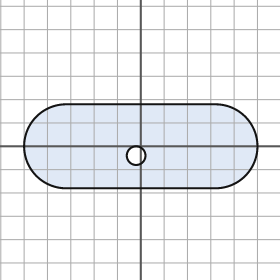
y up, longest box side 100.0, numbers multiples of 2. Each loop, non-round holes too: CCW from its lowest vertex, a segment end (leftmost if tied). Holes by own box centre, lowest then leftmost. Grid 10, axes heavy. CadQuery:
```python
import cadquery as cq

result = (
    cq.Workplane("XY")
    .moveTo(-32.0, -18.0)
    .lineTo(32.0, -18.0)
    .threePointArc((50.0, 0.0), (32.0, 18.0))
    .lineTo(-32.0, 18.0)
    .threePointArc((-50.0, 0.0), (-32.0, -18.0))
    .close()
    .moveTo(-2.0, -4.0)
    .circle(4.0)
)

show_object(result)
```